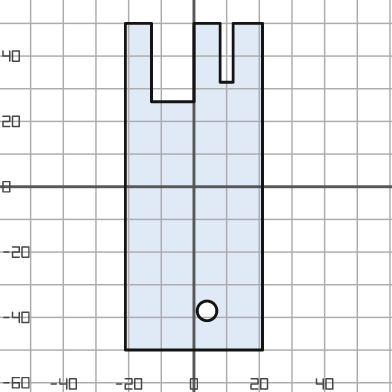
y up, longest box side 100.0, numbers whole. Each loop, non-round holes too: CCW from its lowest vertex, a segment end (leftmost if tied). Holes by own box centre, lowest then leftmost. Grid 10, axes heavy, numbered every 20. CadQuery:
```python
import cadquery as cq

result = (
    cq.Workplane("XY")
    .moveTo(-21.0, -50.0)
    .lineTo(21.0, -50.0)
    .lineTo(21.0, 50.0)
    .lineTo(12.0, 50.0)
    .lineTo(12.0, 32.0)
    .lineTo(8.0, 32.0)
    .lineTo(8.0, 50.0)
    .lineTo(0.0, 50.0)
    .lineTo(0.0, 26.0)
    .lineTo(-13.0, 26.0)
    .lineTo(-13.0, 50.0)
    .lineTo(-21.0, 50.0)
    .close()
    .moveTo(4.0, -38.0)
    .circle(3.0)
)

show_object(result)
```